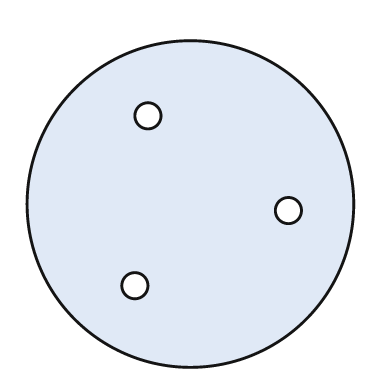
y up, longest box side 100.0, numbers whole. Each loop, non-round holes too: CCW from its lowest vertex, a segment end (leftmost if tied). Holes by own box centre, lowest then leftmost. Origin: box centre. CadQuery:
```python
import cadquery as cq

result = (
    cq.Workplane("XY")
    .moveTo(0.0, 0.0)
    .circle(50.0)
    .moveTo(-17.0, -25.0)
    .circle(4.0)
    .moveTo(30.0, -2.0)
    .circle(4.0)
    .moveTo(-13.0, 27.0)
    .circle(4.0)
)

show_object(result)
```